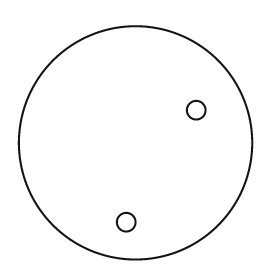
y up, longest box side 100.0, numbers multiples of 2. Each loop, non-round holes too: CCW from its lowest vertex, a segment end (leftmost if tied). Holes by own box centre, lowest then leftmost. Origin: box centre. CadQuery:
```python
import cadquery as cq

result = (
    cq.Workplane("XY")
    .moveTo(0.0, 0.0)
    .circle(50.0)
    .moveTo(-4.0, -34.0)
    .circle(4.0)
    .moveTo(26.0, 14.0)
    .circle(4.0)
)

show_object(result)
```